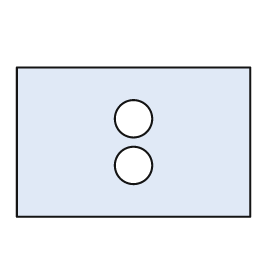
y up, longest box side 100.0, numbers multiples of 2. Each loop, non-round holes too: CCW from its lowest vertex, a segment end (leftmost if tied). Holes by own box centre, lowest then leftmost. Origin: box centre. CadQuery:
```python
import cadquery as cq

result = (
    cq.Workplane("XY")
    .moveTo(-50.0, -32.0)
    .lineTo(50.0, -32.0)
    .lineTo(50.0, 32.0)
    .lineTo(-50.0, 32.0)
    .close()
    .moveTo(0.0, -10.0)
    .circle(8.0)
    .moveTo(0.0, 10.0)
    .circle(8.0)
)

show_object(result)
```